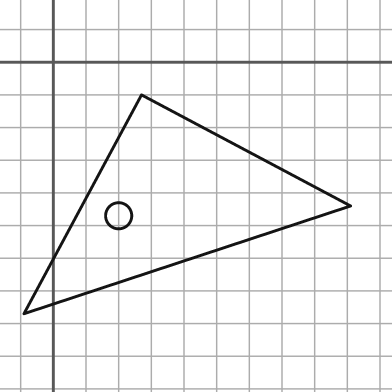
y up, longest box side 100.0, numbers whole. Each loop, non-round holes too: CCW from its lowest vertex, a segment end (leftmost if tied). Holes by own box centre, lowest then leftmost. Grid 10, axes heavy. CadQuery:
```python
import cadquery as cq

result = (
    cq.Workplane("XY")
    .moveTo(-9.0, -77.0)
    .lineTo(91.0, -44.0)
    .lineTo(27.0, -10.0)
    .close()
    .moveTo(20.0, -47.0)
    .circle(4.0)
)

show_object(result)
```